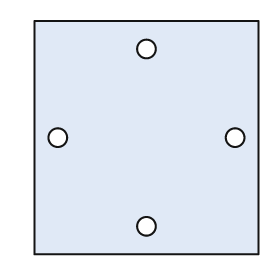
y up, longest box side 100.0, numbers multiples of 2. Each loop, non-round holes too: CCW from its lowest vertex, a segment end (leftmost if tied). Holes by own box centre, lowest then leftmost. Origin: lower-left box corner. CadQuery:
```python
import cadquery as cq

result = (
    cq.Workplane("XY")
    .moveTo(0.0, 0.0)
    .lineTo(96.0, 0.0)
    .lineTo(96.0, 100.0)
    .lineTo(0.0, 100.0)
    .close()
    .moveTo(48.0, 12.0)
    .circle(4.0)
    .moveTo(10.0, 50.0)
    .circle(4.0)
    .moveTo(86.0, 50.0)
    .circle(4.0)
    .moveTo(48.0, 88.0)
    .circle(4.0)
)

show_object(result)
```